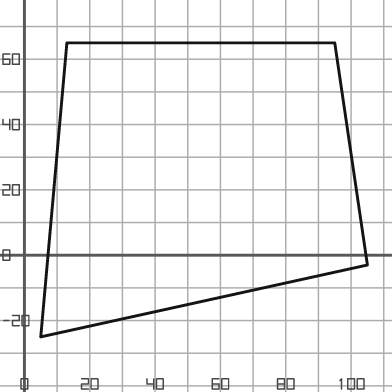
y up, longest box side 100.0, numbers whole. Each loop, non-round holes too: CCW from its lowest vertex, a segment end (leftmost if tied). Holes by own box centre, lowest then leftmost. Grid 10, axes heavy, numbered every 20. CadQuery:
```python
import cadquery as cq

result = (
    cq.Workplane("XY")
    .moveTo(5.0, -25.0)
    .lineTo(105.0, -3.0)
    .lineTo(95.0, 65.0)
    .lineTo(13.0, 65.0)
    .close()
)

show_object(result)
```